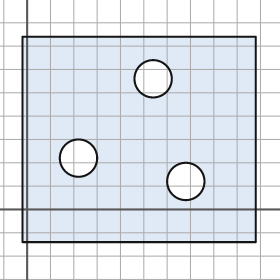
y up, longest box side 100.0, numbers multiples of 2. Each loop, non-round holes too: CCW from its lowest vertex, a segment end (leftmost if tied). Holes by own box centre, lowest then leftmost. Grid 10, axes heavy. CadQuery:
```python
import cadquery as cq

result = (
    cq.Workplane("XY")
    .moveTo(-2.0, -14.0)
    .lineTo(98.0, -14.0)
    .lineTo(98.0, 74.0)
    .lineTo(-2.0, 74.0)
    .close()
    .moveTo(68.0, 12.0)
    .circle(8.0)
    .moveTo(22.0, 22.0)
    .circle(8.0)
    .moveTo(54.0, 56.0)
    .circle(8.0)
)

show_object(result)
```